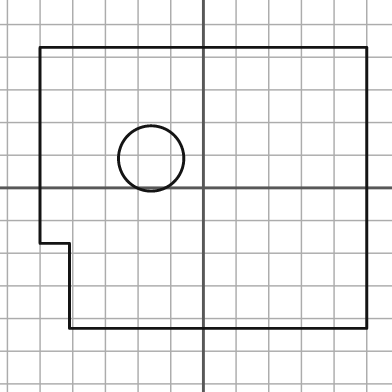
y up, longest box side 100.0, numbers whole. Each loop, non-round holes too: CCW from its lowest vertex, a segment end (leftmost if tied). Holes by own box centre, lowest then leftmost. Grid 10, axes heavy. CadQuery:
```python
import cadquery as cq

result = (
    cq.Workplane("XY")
    .moveTo(-41.0, -43.0)
    .lineTo(50.0, -43.0)
    .lineTo(50.0, 43.0)
    .lineTo(-50.0, 43.0)
    .lineTo(-50.0, -17.0)
    .lineTo(-41.0, -17.0)
    .close()
    .moveTo(-16.0, 9.0)
    .circle(10.0)
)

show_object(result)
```